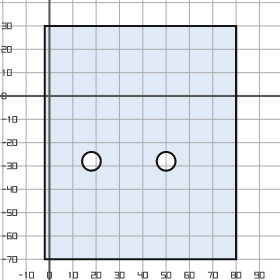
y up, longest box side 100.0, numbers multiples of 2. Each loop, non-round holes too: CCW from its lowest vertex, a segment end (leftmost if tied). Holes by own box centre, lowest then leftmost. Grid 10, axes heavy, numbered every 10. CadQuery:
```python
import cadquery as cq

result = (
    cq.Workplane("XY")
    .moveTo(-2.0, -70.0)
    .lineTo(80.0, -70.0)
    .lineTo(80.0, 30.0)
    .lineTo(-2.0, 30.0)
    .close()
    .moveTo(18.0, -28.0)
    .circle(4.0)
    .moveTo(50.0, -28.0)
    .circle(4.0)
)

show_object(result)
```